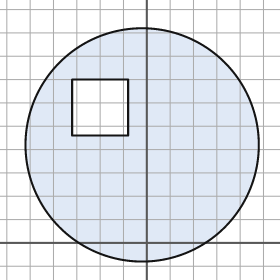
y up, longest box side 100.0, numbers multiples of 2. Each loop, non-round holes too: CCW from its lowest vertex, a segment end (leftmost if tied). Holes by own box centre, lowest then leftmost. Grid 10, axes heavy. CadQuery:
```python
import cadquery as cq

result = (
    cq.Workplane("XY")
    .moveTo(-2.0, 42.0)
    .circle(50.0)
    .moveTo(-32.0, 46.0)
    .lineTo(-8.0, 46.0)
    .lineTo(-8.0, 70.0)
    .lineTo(-32.0, 70.0)
    .close()
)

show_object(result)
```